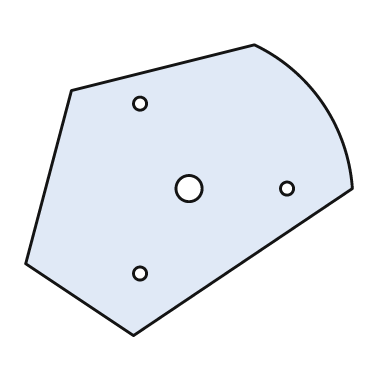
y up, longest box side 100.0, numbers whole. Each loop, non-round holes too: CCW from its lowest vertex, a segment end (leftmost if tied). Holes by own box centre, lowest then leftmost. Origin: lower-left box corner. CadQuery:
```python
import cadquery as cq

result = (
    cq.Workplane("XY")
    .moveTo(33.0, 0.0)
    .lineTo(100.0, 45.0)
    .threePointArc((91.0, 71.0), (70.0, 89.0))
    .lineTo(14.0, 75.0)
    .lineTo(0.0, 22.0)
    .close()
    .moveTo(35.0, 19.0)
    .circle(2.0)
    .moveTo(50.0, 45.0)
    .circle(4.0)
    .moveTo(80.0, 45.0)
    .circle(2.0)
    .moveTo(35.0, 71.0)
    .circle(2.0)
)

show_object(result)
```